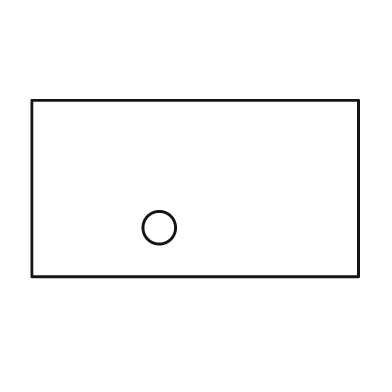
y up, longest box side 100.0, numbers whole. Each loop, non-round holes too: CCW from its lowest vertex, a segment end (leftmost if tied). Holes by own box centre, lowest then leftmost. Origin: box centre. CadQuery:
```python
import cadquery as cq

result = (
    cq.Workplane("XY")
    .moveTo(-50.0, -27.0)
    .lineTo(50.0, -27.0)
    .lineTo(50.0, 27.0)
    .lineTo(-50.0, 27.0)
    .close()
    .moveTo(-11.0, -12.0)
    .circle(5.0)
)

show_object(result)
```